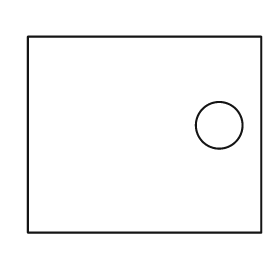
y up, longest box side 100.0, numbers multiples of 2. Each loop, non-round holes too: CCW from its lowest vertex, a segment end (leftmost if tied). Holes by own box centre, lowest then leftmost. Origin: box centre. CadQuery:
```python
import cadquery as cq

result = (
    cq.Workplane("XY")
    .moveTo(-50.0, -42.0)
    .lineTo(50.0, -42.0)
    .lineTo(50.0, 42.0)
    .lineTo(-50.0, 42.0)
    .close()
    .moveTo(32.0, 4.0)
    .circle(10.0)
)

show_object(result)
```